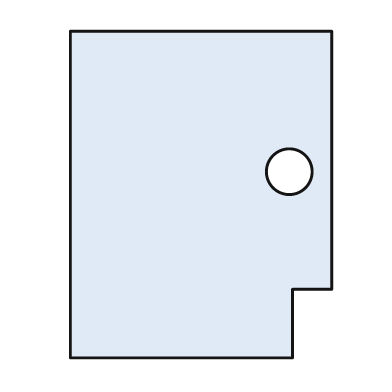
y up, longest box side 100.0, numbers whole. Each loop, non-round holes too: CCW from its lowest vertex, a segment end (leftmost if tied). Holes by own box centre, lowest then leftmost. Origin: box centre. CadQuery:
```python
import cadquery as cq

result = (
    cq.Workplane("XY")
    .moveTo(-40.0, -50.0)
    .lineTo(28.0, -50.0)
    .lineTo(28.0, -29.0)
    .lineTo(40.0, -29.0)
    .lineTo(40.0, 50.0)
    .lineTo(-40.0, 50.0)
    .close()
    .moveTo(27.0, 7.0)
    .circle(7.0)
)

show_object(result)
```